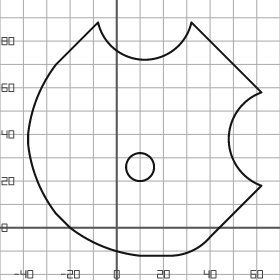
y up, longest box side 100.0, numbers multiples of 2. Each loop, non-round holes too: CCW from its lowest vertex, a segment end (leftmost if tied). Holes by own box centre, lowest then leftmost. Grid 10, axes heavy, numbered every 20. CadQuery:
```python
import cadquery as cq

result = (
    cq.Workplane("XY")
    .moveTo(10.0, -12.0)
    .lineTo(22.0, -12.0)
    .threePointArc((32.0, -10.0), (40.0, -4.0))
    .lineTo(62.0, 18.0)
    .threePointArc((48.0, 38.0), (62.0, 58.0))
    .lineTo(32.0, 88.0)
    .threePointArc((12.0, 72.0), (-8.0, 88.0))
    .lineTo(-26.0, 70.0)
    .threePointArc((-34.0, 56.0), (-38.0, 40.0))
    .lineTo(-38.0, 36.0)
    .threePointArc((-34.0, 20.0), (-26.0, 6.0))
    .lineTo(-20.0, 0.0)
    .threePointArc((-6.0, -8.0), (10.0, -12.0))
    .close()
    .moveTo(10.0, 26.0)
    .circle(6.0)
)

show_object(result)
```